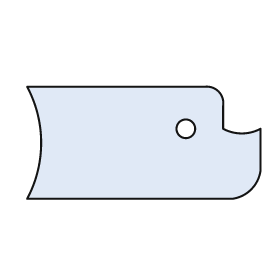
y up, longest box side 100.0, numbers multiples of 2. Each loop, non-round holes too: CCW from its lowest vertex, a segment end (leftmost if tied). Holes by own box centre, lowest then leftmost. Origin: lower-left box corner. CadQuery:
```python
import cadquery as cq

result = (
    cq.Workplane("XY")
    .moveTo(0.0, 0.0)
    .lineTo(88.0, 0.0)
    .threePointArc((96.0, 4.0), (100.0, 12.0))
    .lineTo(100.0, 30.0)
    .threePointArc((92.0, 28.0), (84.0, 30.0))
    .lineTo(84.0, 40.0)
    .threePointArc((82.0, 46.0), (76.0, 48.0))
    .lineTo(0.0, 48.0)
    .threePointArc((6.0, 24.0), (0.0, 0.0))
    .close()
    .moveTo(68.0, 30.0)
    .circle(4.0)
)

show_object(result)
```